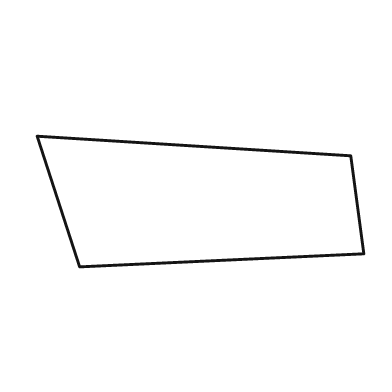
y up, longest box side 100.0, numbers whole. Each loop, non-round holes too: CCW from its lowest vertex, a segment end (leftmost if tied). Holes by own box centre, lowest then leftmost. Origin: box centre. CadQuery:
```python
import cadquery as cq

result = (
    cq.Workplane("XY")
    .moveTo(-37.0, -20.0)
    .lineTo(50.0, -16.0)
    .lineTo(46.0, 14.0)
    .lineTo(-50.0, 20.0)
    .close()
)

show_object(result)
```